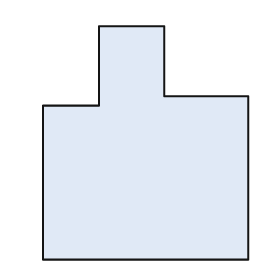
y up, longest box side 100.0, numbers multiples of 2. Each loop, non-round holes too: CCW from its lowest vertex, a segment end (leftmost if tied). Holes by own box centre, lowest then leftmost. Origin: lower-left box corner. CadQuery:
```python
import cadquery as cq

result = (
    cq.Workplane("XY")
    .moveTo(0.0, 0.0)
    .lineTo(88.0, 0.0)
    .lineTo(88.0, 70.0)
    .lineTo(52.0, 70.0)
    .lineTo(52.0, 100.0)
    .lineTo(24.0, 100.0)
    .lineTo(24.0, 66.0)
    .lineTo(0.0, 66.0)
    .close()
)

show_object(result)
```